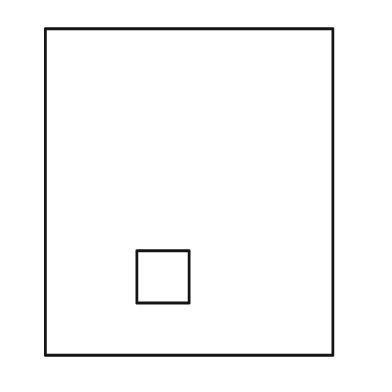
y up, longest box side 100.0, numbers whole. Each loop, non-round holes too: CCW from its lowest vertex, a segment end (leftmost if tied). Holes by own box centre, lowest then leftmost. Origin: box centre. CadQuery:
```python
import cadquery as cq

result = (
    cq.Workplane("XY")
    .moveTo(-44.0, -50.0)
    .lineTo(44.0, -50.0)
    .lineTo(44.0, 50.0)
    .lineTo(-44.0, 50.0)
    .close()
    .moveTo(-16.0, -34.0)
    .lineTo(0.0, -34.0)
    .lineTo(0.0, -18.0)
    .lineTo(-16.0, -18.0)
    .close()
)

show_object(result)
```